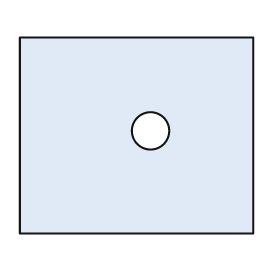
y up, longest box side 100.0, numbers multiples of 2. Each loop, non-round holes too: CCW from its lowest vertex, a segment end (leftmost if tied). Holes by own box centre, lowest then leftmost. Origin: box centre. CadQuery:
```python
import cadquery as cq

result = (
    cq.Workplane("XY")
    .moveTo(-50.0, -42.0)
    .lineTo(50.0, -42.0)
    .lineTo(50.0, 42.0)
    .lineTo(-50.0, 42.0)
    .close()
    .moveTo(6.0, 2.0)
    .circle(8.0)
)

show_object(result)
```